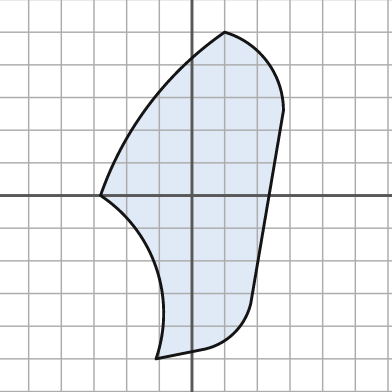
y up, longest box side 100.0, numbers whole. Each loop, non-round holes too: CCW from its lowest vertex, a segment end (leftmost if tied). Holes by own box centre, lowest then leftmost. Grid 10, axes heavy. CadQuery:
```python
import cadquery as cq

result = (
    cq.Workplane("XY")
    .moveTo(-11.0, -50.0)
    .lineTo(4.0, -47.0)
    .threePointArc((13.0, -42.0), (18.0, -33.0))
    .lineTo(28.0, 26.0)
    .threePointArc((23.0, 41.0), (10.0, 50.0))
    .threePointArc((-13.0, 28.0), (-28.0, 0.0))
    .threePointArc((-11.0, -22.0), (-11.0, -50.0))
    .close()
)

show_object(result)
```